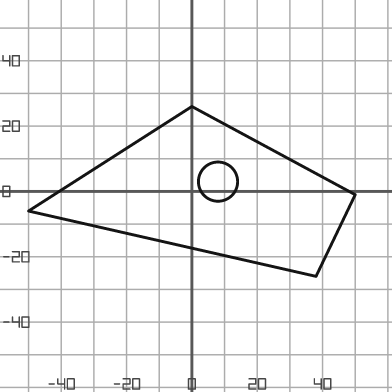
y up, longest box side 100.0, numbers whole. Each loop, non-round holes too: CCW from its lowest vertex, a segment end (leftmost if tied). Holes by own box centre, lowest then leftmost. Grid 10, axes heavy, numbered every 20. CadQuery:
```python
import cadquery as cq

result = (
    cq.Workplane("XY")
    .moveTo(38.0, -26.0)
    .lineTo(50.0, -1.0)
    .lineTo(0.0, 26.0)
    .lineTo(-50.0, -6.0)
    .close()
    .moveTo(8.0, 3.0)
    .circle(6.0)
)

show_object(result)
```